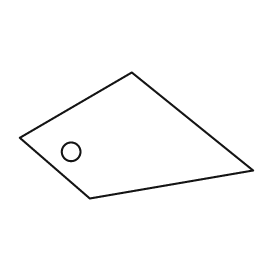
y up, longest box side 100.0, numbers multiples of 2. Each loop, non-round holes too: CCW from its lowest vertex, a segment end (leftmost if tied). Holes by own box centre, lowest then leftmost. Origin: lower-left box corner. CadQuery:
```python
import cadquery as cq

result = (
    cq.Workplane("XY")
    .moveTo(30.0, 0.0)
    .lineTo(100.0, 12.0)
    .lineTo(48.0, 54.0)
    .lineTo(0.0, 26.0)
    .close()
    .moveTo(22.0, 20.0)
    .circle(4.0)
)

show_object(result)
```